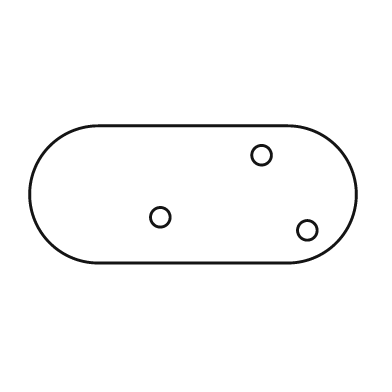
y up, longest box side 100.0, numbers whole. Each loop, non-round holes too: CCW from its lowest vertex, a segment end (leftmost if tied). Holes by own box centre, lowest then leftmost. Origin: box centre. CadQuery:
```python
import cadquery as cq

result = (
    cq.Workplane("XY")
    .moveTo(-29.0, -21.0)
    .lineTo(29.0, -21.0)
    .threePointArc((50.0, 0.0), (29.0, 21.0))
    .lineTo(-29.0, 21.0)
    .threePointArc((-50.0, 0.0), (-29.0, -21.0))
    .close()
    .moveTo(35.0, -11.0)
    .circle(3.0)
    .moveTo(-10.0, -7.0)
    .circle(3.0)
    .moveTo(21.0, 12.0)
    .circle(3.0)
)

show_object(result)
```